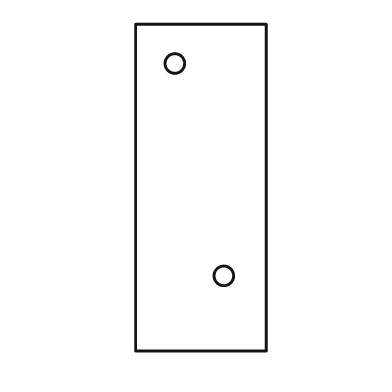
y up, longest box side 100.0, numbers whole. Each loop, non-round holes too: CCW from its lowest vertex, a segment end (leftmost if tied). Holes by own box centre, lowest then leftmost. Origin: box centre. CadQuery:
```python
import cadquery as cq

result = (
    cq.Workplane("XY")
    .moveTo(-20.0, -50.0)
    .lineTo(20.0, -50.0)
    .lineTo(20.0, 50.0)
    .lineTo(-20.0, 50.0)
    .close()
    .moveTo(7.0, -27.0)
    .circle(3.0)
    .moveTo(-8.0, 38.0)
    .circle(3.0)
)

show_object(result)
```